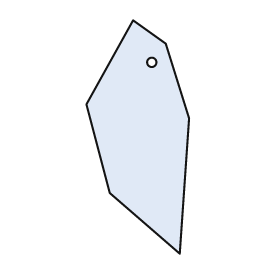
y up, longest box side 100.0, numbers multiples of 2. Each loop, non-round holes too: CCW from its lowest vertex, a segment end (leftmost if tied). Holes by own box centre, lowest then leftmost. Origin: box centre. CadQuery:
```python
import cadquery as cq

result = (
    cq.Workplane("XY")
    .moveTo(18.0, -50.0)
    .lineTo(22.0, 8.0)
    .lineTo(12.0, 40.0)
    .lineTo(-2.0, 50.0)
    .lineTo(-22.0, 14.0)
    .lineTo(-12.0, -24.0)
    .close()
    .moveTo(6.0, 32.0)
    .circle(2.0)
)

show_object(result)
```